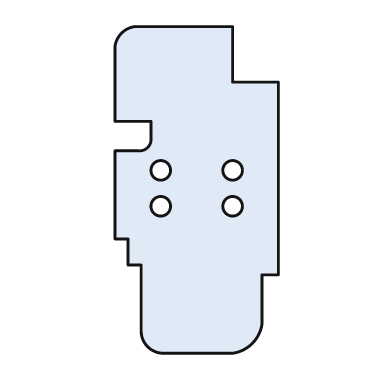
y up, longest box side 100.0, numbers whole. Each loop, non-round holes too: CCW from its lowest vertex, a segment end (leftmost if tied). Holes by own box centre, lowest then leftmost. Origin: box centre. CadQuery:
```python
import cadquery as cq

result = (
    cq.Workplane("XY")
    .moveTo(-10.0, -50.0)
    .lineTo(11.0, -50.0)
    .threePointArc((17.0, -47.0), (20.0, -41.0))
    .lineTo(20.0, -26.0)
    .lineTo(25.0, -26.0)
    .lineTo(25.0, 33.0)
    .lineTo(11.0, 33.0)
    .lineTo(11.0, 50.0)
    .lineTo(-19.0, 50.0)
    .threePointArc((-23.0, 48.0), (-25.0, 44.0))
    .lineTo(-25.0, 21.0)
    .lineTo(-14.0, 21.0)
    .lineTo(-14.0, 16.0)
    .threePointArc((-15.0, 13.0), (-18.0, 12.0))
    .lineTo(-25.0, 12.0)
    .lineTo(-25.0, -15.0)
    .lineTo(-21.0, -15.0)
    .lineTo(-21.0, -23.0)
    .lineTo(-17.0, -23.0)
    .lineTo(-17.0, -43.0)
    .threePointArc((-15.0, -48.0), (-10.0, -50.0))
    .close()
    .moveTo(-11.0, -5.0)
    .circle(3.0)
    .moveTo(11.0, -5.0)
    .circle(3.0)
    .moveTo(-11.0, 6.0)
    .circle(3.0)
    .moveTo(11.0, 6.0)
    .circle(3.0)
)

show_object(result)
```